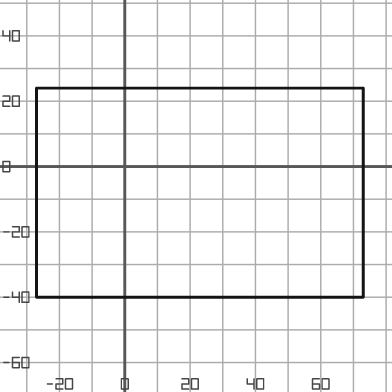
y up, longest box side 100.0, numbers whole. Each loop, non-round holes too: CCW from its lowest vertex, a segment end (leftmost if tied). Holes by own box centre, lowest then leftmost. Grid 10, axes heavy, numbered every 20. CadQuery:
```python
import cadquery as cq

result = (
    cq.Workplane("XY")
    .moveTo(-27.0, -40.0)
    .lineTo(73.0, -40.0)
    .lineTo(73.0, 24.0)
    .lineTo(-27.0, 24.0)
    .close()
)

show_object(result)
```